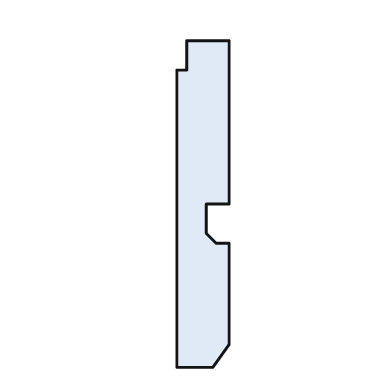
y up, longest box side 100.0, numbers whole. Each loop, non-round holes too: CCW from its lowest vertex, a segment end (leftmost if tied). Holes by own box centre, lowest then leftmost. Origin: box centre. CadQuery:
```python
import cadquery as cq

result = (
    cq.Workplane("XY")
    .moveTo(-8.0, -50.0)
    .lineTo(3.0, -50.0)
    .lineTo(8.0, -43.0)
    .lineTo(8.0, -12.0)
    .lineTo(4.0, -12.0)
    .lineTo(1.0, -9.0)
    .lineTo(1.0, 0.0)
    .lineTo(8.0, 0.0)
    .lineTo(8.0, 50.0)
    .lineTo(-5.0, 50.0)
    .lineTo(-5.0, 41.0)
    .lineTo(-8.0, 41.0)
    .close()
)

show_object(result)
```